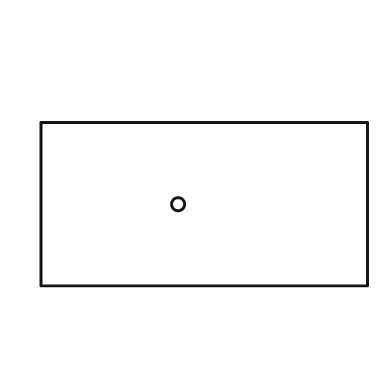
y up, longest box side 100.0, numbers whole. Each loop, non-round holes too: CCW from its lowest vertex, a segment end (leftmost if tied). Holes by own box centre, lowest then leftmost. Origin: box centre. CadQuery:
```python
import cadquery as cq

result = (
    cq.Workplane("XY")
    .moveTo(-50.0, -25.0)
    .lineTo(50.0, -25.0)
    .lineTo(50.0, 25.0)
    .lineTo(-50.0, 25.0)
    .close()
    .moveTo(-8.0, 0.0)
    .circle(2.0)
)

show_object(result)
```